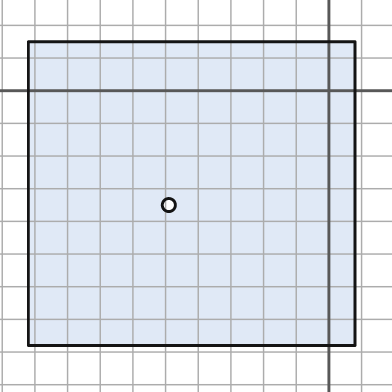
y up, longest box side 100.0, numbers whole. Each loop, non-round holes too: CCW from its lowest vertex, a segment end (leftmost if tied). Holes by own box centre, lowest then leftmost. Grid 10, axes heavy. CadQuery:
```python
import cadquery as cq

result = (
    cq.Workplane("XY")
    .moveTo(-92.0, -78.0)
    .lineTo(8.0, -78.0)
    .lineTo(8.0, 15.0)
    .lineTo(-92.0, 15.0)
    .close()
    .moveTo(-49.0, -35.0)
    .circle(2.0)
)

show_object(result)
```